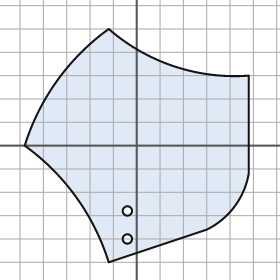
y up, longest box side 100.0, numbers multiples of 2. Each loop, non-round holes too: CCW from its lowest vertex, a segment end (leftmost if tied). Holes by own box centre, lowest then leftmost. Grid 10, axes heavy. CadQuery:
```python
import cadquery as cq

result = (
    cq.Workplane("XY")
    .moveTo(-12.0, -50.0)
    .lineTo(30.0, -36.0)
    .threePointArc((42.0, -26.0), (48.0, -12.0))
    .lineTo(48.0, 30.0)
    .threePointArc((16.0, 34.0), (-12.0, 50.0))
    .threePointArc((-34.0, 28.0), (-48.0, 0.0))
    .threePointArc((-26.0, -22.0), (-12.0, -50.0))
    .close()
    .moveTo(-4.0, -40.0)
    .circle(2.0)
    .moveTo(-4.0, -28.0)
    .circle(2.0)
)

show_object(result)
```